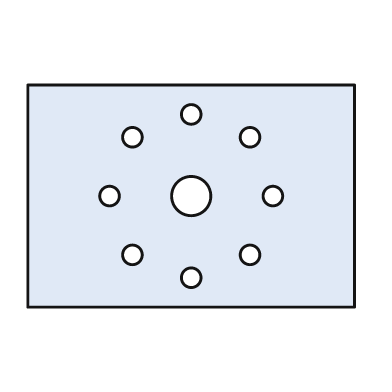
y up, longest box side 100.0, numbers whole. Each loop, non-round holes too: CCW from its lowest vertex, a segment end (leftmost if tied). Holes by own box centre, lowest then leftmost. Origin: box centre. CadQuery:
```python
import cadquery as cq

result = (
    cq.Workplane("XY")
    .moveTo(-50.0, -34.0)
    .lineTo(50.0, -34.0)
    .lineTo(50.0, 34.0)
    .lineTo(-50.0, 34.0)
    .close()
    .moveTo(0.0, -25.0)
    .circle(3.0)
    .moveTo(-18.0, -18.0)
    .circle(3.0)
    .moveTo(18.0, -18.0)
    .circle(3.0)
    .moveTo(-25.0, 0.0)
    .circle(3.0)
    .moveTo(0.0, 0.0)
    .circle(6.0)
    .moveTo(25.0, 0.0)
    .circle(3.0)
    .moveTo(-18.0, 18.0)
    .circle(3.0)
    .moveTo(18.0, 18.0)
    .circle(3.0)
    .moveTo(0.0, 25.0)
    .circle(3.0)
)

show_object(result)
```